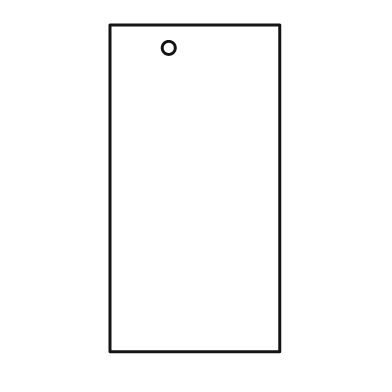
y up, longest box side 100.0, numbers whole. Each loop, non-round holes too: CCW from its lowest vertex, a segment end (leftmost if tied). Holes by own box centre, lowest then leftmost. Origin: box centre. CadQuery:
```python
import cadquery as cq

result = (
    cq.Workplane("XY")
    .moveTo(-26.0, -50.0)
    .lineTo(26.0, -50.0)
    .lineTo(26.0, 50.0)
    .lineTo(-26.0, 50.0)
    .close()
    .moveTo(-8.0, 43.0)
    .circle(2.0)
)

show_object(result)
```